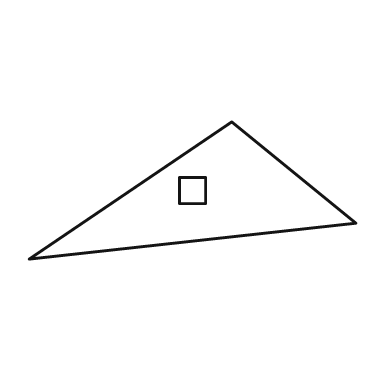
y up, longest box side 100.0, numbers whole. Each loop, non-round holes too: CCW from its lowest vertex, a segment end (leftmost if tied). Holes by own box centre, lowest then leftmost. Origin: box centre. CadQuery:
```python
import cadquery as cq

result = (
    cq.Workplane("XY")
    .moveTo(-50.0, -21.0)
    .lineTo(50.0, -10.0)
    .lineTo(12.0, 21.0)
    .close()
    .moveTo(-4.0, -4.0)
    .lineTo(4.0, -4.0)
    .lineTo(4.0, 4.0)
    .lineTo(-4.0, 4.0)
    .close()
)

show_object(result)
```